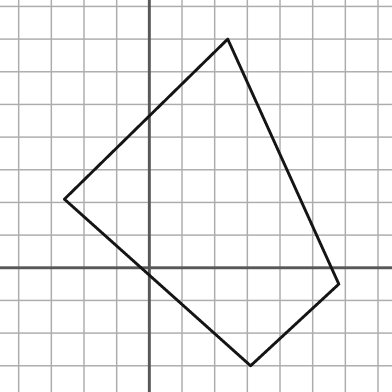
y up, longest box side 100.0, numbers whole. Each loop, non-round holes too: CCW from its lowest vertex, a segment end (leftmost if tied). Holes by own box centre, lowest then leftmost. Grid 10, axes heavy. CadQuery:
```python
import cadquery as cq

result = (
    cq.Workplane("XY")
    .moveTo(31.0, -30.0)
    .lineTo(58.0, -5.0)
    .lineTo(24.0, 70.0)
    .lineTo(-26.0, 21.0)
    .close()
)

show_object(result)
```